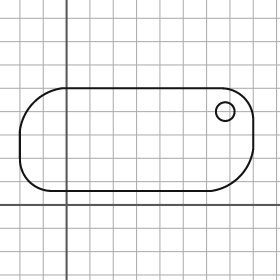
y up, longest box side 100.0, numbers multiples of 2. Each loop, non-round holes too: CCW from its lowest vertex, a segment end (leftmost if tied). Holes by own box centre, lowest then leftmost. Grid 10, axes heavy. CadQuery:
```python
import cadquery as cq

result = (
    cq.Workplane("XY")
    .moveTo(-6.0, 6.0)
    .lineTo(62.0, 6.0)
    .threePointArc((74.0, 12.0), (80.0, 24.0))
    .lineTo(80.0, 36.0)
    .threePointArc((76.0, 46.0), (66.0, 50.0))
    .lineTo(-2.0, 50.0)
    .threePointArc((-14.0, 44.0), (-20.0, 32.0))
    .lineTo(-20.0, 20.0)
    .threePointArc((-16.0, 10.0), (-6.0, 6.0))
    .close()
    .moveTo(68.0, 40.0)
    .circle(4.0)
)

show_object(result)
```